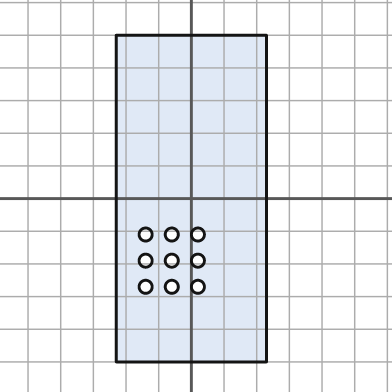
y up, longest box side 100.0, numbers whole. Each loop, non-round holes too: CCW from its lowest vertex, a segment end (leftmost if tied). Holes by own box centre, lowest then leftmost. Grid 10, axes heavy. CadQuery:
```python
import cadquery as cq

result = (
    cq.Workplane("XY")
    .moveTo(-23.0, -50.0)
    .lineTo(23.0, -50.0)
    .lineTo(23.0, 50.0)
    .lineTo(-23.0, 50.0)
    .close()
    .moveTo(-14.0, -27.0)
    .circle(2.0)
    .moveTo(-6.0, -27.0)
    .circle(2.0)
    .moveTo(2.0, -27.0)
    .circle(2.0)
    .moveTo(-14.0, -19.0)
    .circle(2.0)
    .moveTo(-6.0, -19.0)
    .circle(2.0)
    .moveTo(2.0, -19.0)
    .circle(2.0)
    .moveTo(-14.0, -11.0)
    .circle(2.0)
    .moveTo(-6.0, -11.0)
    .circle(2.0)
    .moveTo(2.0, -11.0)
    .circle(2.0)
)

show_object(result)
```